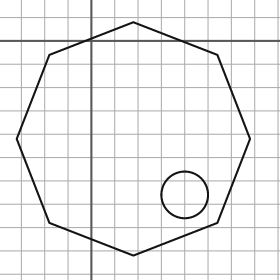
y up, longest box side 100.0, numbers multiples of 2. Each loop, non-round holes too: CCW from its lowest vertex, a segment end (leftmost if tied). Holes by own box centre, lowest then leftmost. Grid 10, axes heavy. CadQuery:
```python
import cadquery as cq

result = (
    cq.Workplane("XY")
    .moveTo(18.0, -92.0)
    .lineTo(54.0, -78.0)
    .lineTo(68.0, -42.0)
    .lineTo(54.0, -6.0)
    .lineTo(18.0, 8.0)
    .lineTo(-18.0, -6.0)
    .lineTo(-32.0, -42.0)
    .lineTo(-18.0, -78.0)
    .close()
    .moveTo(40.0, -66.0)
    .circle(10.0)
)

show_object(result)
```